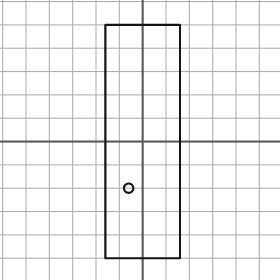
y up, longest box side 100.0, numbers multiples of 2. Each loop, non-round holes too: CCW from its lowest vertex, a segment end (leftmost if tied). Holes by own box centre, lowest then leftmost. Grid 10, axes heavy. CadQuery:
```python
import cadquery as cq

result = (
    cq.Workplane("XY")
    .moveTo(-16.0, -50.0)
    .lineTo(16.0, -50.0)
    .lineTo(16.0, 50.0)
    .lineTo(-16.0, 50.0)
    .close()
    .moveTo(-6.0, -20.0)
    .circle(2.0)
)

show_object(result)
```